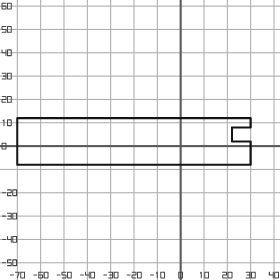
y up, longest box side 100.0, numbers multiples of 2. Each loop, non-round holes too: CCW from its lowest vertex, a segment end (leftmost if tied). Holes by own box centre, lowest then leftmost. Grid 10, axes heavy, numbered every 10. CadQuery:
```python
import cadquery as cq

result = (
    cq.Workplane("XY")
    .moveTo(-70.0, -8.0)
    .lineTo(30.0, -8.0)
    .lineTo(30.0, 2.0)
    .lineTo(22.0, 2.0)
    .lineTo(22.0, 8.0)
    .lineTo(30.0, 8.0)
    .lineTo(30.0, 12.0)
    .lineTo(-70.0, 12.0)
    .close()
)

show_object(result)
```